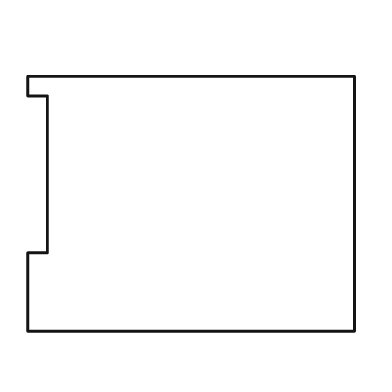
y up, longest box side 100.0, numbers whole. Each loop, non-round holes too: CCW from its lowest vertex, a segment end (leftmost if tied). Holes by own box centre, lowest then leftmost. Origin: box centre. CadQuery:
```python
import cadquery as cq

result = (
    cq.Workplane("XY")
    .moveTo(-50.0, -39.0)
    .lineTo(50.0, -39.0)
    .lineTo(50.0, 39.0)
    .lineTo(-50.0, 39.0)
    .lineTo(-50.0, 33.0)
    .lineTo(-44.0, 33.0)
    .lineTo(-44.0, -15.0)
    .lineTo(-50.0, -15.0)
    .close()
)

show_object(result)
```